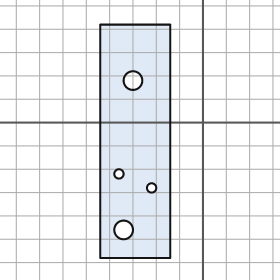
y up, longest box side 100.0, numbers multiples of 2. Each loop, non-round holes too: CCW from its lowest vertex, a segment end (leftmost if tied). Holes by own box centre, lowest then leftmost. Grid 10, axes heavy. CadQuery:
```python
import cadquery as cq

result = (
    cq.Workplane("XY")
    .moveTo(-44.0, -58.0)
    .lineTo(-14.0, -58.0)
    .lineTo(-14.0, 42.0)
    .lineTo(-44.0, 42.0)
    .close()
    .moveTo(-34.0, -46.0)
    .circle(4.0)
    .moveTo(-22.0, -28.0)
    .circle(2.0)
    .moveTo(-36.0, -22.0)
    .circle(2.0)
    .moveTo(-30.0, 18.0)
    .circle(4.0)
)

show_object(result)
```